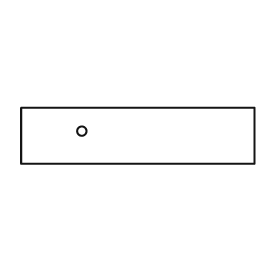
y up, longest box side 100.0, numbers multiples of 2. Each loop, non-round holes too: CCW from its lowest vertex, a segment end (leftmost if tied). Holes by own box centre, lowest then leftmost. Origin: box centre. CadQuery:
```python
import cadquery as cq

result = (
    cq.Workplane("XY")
    .moveTo(-50.0, -12.0)
    .lineTo(50.0, -12.0)
    .lineTo(50.0, 12.0)
    .lineTo(-50.0, 12.0)
    .close()
    .moveTo(-24.0, 2.0)
    .circle(2.0)
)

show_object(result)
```